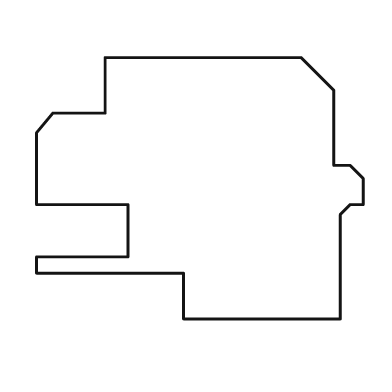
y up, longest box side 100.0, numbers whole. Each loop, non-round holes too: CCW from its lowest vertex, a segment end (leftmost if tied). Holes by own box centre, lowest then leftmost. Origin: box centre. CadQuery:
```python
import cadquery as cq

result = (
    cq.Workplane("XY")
    .moveTo(-5.0, -40.0)
    .lineTo(43.0, -40.0)
    .lineTo(43.0, -8.0)
    .lineTo(46.0, -5.0)
    .lineTo(50.0, -5.0)
    .lineTo(50.0, 3.0)
    .lineTo(46.0, 7.0)
    .lineTo(41.0, 7.0)
    .lineTo(41.0, 30.0)
    .lineTo(31.0, 40.0)
    .lineTo(-29.0, 40.0)
    .lineTo(-29.0, 23.0)
    .lineTo(-45.0, 23.0)
    .lineTo(-50.0, 17.0)
    .lineTo(-50.0, -5.0)
    .lineTo(-22.0, -5.0)
    .lineTo(-22.0, -21.0)
    .lineTo(-50.0, -21.0)
    .lineTo(-50.0, -26.0)
    .lineTo(-5.0, -26.0)
    .close()
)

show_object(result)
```